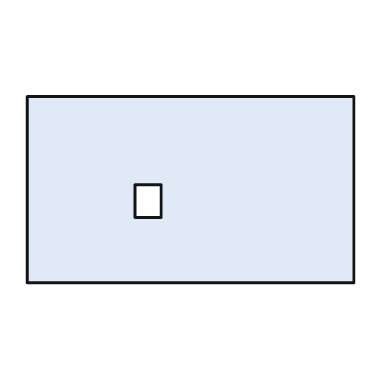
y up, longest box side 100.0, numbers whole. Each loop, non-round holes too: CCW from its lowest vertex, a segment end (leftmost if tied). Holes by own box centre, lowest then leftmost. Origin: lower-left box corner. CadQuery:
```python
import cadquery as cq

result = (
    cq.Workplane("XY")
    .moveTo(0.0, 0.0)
    .lineTo(100.0, 0.0)
    .lineTo(100.0, 57.0)
    .lineTo(0.0, 57.0)
    .close()
    .moveTo(33.0, 20.0)
    .lineTo(41.0, 20.0)
    .lineTo(41.0, 30.0)
    .lineTo(33.0, 30.0)
    .close()
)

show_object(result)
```